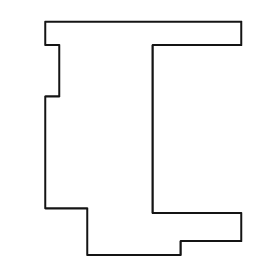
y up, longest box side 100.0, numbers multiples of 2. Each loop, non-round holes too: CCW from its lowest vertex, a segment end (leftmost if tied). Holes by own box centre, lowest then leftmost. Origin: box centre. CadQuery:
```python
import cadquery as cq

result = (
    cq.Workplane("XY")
    .moveTo(-24.0, -50.0)
    .lineTo(16.0, -50.0)
    .lineTo(16.0, -44.0)
    .lineTo(42.0, -44.0)
    .lineTo(42.0, -32.0)
    .lineTo(4.0, -32.0)
    .lineTo(4.0, 40.0)
    .lineTo(42.0, 40.0)
    .lineTo(42.0, 50.0)
    .lineTo(-42.0, 50.0)
    .lineTo(-42.0, 40.0)
    .lineTo(-36.0, 40.0)
    .lineTo(-36.0, 18.0)
    .lineTo(-42.0, 18.0)
    .lineTo(-42.0, -30.0)
    .lineTo(-24.0, -30.0)
    .close()
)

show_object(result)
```